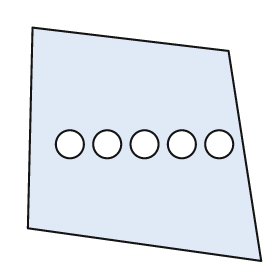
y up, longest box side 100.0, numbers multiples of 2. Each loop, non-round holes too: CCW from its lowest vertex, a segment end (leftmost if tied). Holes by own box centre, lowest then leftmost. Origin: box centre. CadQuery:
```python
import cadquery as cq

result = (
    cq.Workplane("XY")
    .moveTo(50.0, -50.0)
    .lineTo(36.0, 40.0)
    .lineTo(-48.0, 50.0)
    .lineTo(-50.0, -36.0)
    .close()
    .moveTo(-32.0, 0.0)
    .circle(6.0)
    .moveTo(-16.0, 0.0)
    .circle(6.0)
    .moveTo(0.0, 0.0)
    .circle(6.0)
    .moveTo(16.0, 0.0)
    .circle(6.0)
    .moveTo(32.0, 0.0)
    .circle(6.0)
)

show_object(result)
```